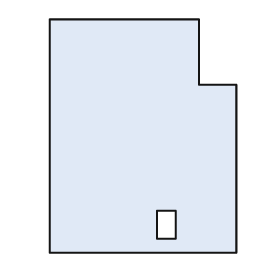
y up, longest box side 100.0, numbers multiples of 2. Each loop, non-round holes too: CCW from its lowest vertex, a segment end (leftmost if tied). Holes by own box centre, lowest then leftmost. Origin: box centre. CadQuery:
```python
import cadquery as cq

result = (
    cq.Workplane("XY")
    .moveTo(-40.0, -50.0)
    .lineTo(40.0, -50.0)
    .lineTo(40.0, 22.0)
    .lineTo(24.0, 22.0)
    .lineTo(24.0, 50.0)
    .lineTo(-40.0, 50.0)
    .close()
    .moveTo(6.0, -44.0)
    .lineTo(14.0, -44.0)
    .lineTo(14.0, -32.0)
    .lineTo(6.0, -32.0)
    .close()
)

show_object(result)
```